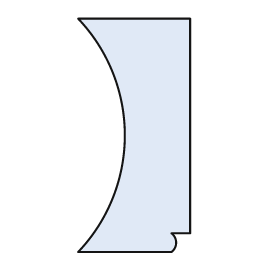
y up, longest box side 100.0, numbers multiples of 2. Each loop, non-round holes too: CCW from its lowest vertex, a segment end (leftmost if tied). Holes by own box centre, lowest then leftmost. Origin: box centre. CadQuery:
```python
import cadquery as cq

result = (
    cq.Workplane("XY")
    .moveTo(-24.0, -50.0)
    .lineTo(16.0, -50.0)
    .threePointArc((18.0, -46.0), (16.0, -42.0))
    .lineTo(24.0, -42.0)
    .lineTo(24.0, 50.0)
    .lineTo(-24.0, 50.0)
    .threePointArc((-4.0, 0.0), (-24.0, -50.0))
    .close()
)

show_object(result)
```